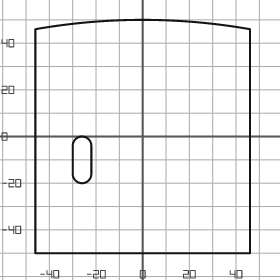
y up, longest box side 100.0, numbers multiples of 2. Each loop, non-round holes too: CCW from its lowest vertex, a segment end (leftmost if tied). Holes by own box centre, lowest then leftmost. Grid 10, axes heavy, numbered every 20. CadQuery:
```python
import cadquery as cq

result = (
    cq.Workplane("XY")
    .moveTo(-46.0, -50.0)
    .lineTo(46.0, -50.0)
    .lineTo(46.0, 46.0)
    .threePointArc((0.0, 50.0), (-46.0, 46.0))
    .close()
    .moveTo(-30.0, -16.0)
    .threePointArc((-26.0, -20.0), (-22.0, -16.0))
    .lineTo(-22.0, -4.0)
    .threePointArc((-26.0, 0.0), (-30.0, -4.0))
    .close()
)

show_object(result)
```